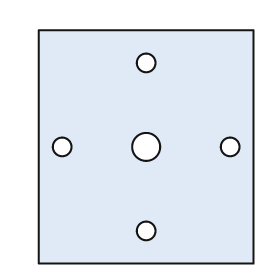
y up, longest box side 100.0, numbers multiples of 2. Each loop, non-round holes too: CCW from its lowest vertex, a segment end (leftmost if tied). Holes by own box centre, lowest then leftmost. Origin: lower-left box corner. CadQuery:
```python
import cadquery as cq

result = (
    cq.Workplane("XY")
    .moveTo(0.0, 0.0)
    .lineTo(92.0, 0.0)
    .lineTo(92.0, 100.0)
    .lineTo(0.0, 100.0)
    .close()
    .moveTo(46.0, 14.0)
    .circle(4.0)
    .moveTo(10.0, 50.0)
    .circle(4.0)
    .moveTo(46.0, 50.0)
    .circle(6.0)
    .moveTo(82.0, 50.0)
    .circle(4.0)
    .moveTo(46.0, 86.0)
    .circle(4.0)
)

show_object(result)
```